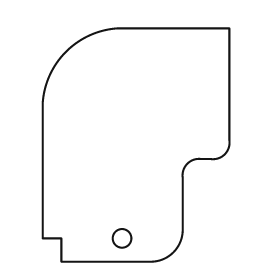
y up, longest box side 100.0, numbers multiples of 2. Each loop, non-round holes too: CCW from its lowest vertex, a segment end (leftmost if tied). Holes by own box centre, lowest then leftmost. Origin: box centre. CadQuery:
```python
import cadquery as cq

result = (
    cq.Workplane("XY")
    .moveTo(-32.0, -50.0)
    .lineTo(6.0, -50.0)
    .threePointArc((16.0, -46.0), (20.0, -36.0))
    .lineTo(20.0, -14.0)
    .threePointArc((22.0, -8.0), (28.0, -6.0))
    .lineTo(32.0, -6.0)
    .threePointArc((38.0, -4.0), (40.0, 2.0))
    .lineTo(40.0, 50.0)
    .lineTo(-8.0, 50.0)
    .threePointArc((-30.0, 40.0), (-40.0, 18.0))
    .lineTo(-40.0, -40.0)
    .lineTo(-32.0, -40.0)
    .close()
    .moveTo(-6.0, -40.0)
    .circle(4.0)
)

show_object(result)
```